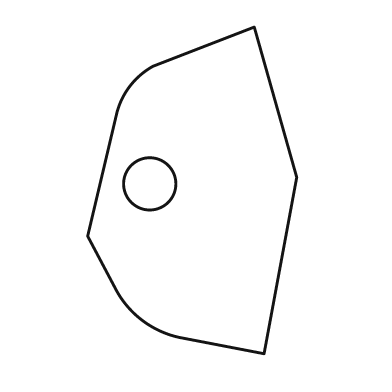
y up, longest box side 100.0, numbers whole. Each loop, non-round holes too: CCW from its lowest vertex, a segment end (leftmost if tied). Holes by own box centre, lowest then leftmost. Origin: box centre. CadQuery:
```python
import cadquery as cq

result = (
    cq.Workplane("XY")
    .moveTo(22.0, -50.0)
    .lineTo(32.0, 4.0)
    .lineTo(19.0, 50.0)
    .lineTo(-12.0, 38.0)
    .threePointArc((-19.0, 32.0), (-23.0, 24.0))
    .lineTo(-32.0, -14.0)
    .lineTo(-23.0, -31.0)
    .threePointArc((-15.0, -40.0), (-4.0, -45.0))
    .close()
    .moveTo(-13.0, 2.0)
    .circle(8.0)
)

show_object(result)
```